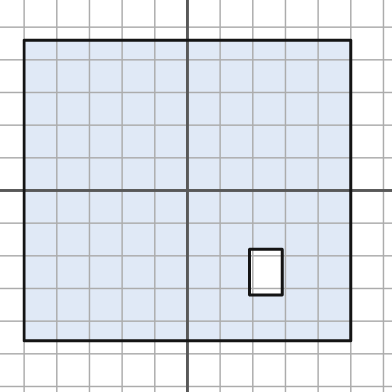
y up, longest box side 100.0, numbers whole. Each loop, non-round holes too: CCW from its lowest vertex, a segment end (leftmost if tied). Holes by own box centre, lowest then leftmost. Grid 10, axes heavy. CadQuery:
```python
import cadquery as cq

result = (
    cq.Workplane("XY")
    .moveTo(-50.0, -46.0)
    .lineTo(50.0, -46.0)
    .lineTo(50.0, 46.0)
    .lineTo(-50.0, 46.0)
    .close()
    .moveTo(19.0, -32.0)
    .lineTo(29.0, -32.0)
    .lineTo(29.0, -18.0)
    .lineTo(19.0, -18.0)
    .close()
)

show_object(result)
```